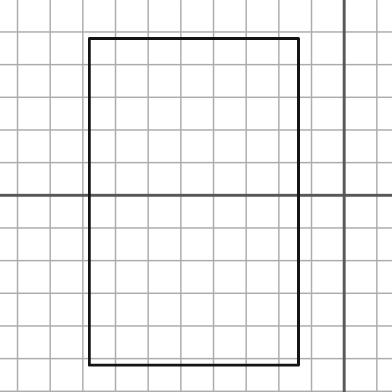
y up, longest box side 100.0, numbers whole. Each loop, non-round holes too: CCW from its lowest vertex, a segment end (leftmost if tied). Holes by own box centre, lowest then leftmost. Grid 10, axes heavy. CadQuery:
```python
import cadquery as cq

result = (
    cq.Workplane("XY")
    .moveTo(-78.0, -52.0)
    .lineTo(-14.0, -52.0)
    .lineTo(-14.0, 48.0)
    .lineTo(-78.0, 48.0)
    .close()
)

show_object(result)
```